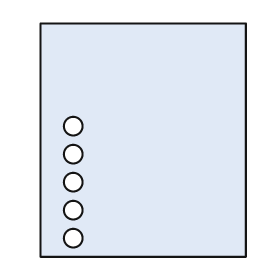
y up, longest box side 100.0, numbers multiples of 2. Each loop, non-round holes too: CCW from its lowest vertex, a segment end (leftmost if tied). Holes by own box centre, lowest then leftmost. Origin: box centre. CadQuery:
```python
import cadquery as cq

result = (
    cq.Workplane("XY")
    .moveTo(-44.0, -50.0)
    .lineTo(44.0, -50.0)
    .lineTo(44.0, 50.0)
    .lineTo(-44.0, 50.0)
    .close()
    .moveTo(-30.0, -42.0)
    .circle(4.0)
    .moveTo(-30.0, -30.0)
    .circle(4.0)
    .moveTo(-30.0, -18.0)
    .circle(4.0)
    .moveTo(-30.0, -6.0)
    .circle(4.0)
    .moveTo(-30.0, 6.0)
    .circle(4.0)
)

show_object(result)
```